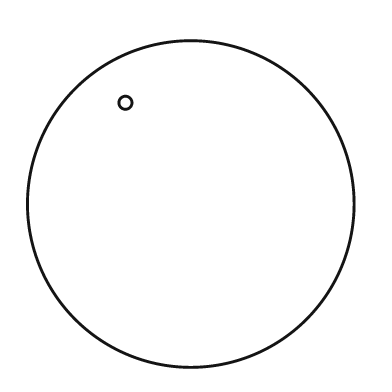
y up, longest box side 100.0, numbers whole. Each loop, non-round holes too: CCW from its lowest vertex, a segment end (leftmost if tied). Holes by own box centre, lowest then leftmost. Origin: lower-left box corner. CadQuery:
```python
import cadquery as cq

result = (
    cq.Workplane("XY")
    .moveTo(50.0, 50.0)
    .circle(50.0)
    .moveTo(30.0, 81.0)
    .circle(2.0)
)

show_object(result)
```